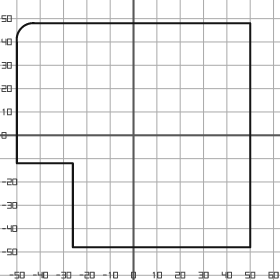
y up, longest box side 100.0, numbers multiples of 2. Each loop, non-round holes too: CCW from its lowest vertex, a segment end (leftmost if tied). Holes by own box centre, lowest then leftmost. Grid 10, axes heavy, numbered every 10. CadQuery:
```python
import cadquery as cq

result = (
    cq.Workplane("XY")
    .moveTo(-26.0, -48.0)
    .lineTo(50.0, -48.0)
    .lineTo(50.0, 48.0)
    .lineTo(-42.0, 48.0)
    .threePointArc((-48.0, 46.0), (-50.0, 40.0))
    .lineTo(-50.0, -12.0)
    .lineTo(-26.0, -12.0)
    .close()
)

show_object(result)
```